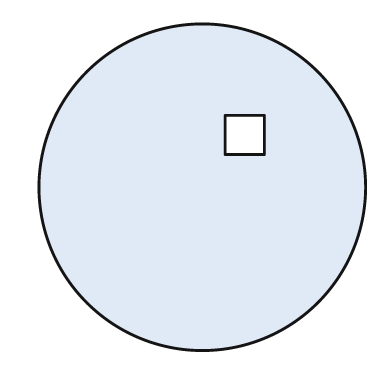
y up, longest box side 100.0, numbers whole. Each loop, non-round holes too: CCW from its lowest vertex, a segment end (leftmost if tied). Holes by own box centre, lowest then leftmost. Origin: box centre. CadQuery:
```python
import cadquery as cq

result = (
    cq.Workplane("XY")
    .moveTo(0.0, 0.0)
    .circle(50.0)
    .moveTo(7.0, 10.0)
    .lineTo(19.0, 10.0)
    .lineTo(19.0, 22.0)
    .lineTo(7.0, 22.0)
    .close()
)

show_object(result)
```